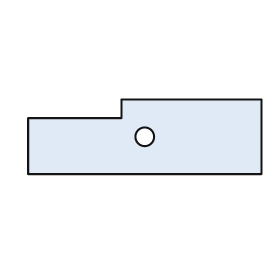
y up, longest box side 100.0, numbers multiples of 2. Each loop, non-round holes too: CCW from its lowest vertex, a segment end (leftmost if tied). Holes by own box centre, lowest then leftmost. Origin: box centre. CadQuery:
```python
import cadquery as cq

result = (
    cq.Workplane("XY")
    .moveTo(-50.0, -16.0)
    .lineTo(50.0, -16.0)
    .lineTo(50.0, 16.0)
    .lineTo(-10.0, 16.0)
    .lineTo(-10.0, 8.0)
    .lineTo(-50.0, 8.0)
    .close()
    .moveTo(0.0, 0.0)
    .circle(4.0)
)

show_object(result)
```